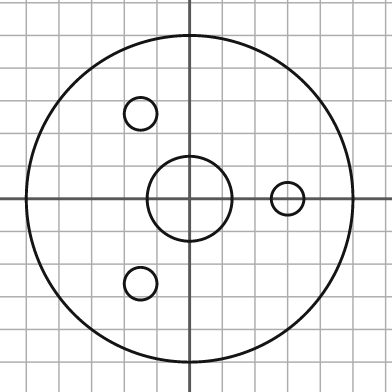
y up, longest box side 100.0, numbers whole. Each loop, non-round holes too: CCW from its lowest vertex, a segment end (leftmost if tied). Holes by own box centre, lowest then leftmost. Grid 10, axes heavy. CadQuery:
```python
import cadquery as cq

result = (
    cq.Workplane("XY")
    .moveTo(0.0, 0.0)
    .circle(50.0)
    .moveTo(-15.0, -26.0)
    .circle(5.0)
    .moveTo(0.0, 0.0)
    .circle(13.0)
    .moveTo(30.0, 0.0)
    .circle(5.0)
    .moveTo(-15.0, 26.0)
    .circle(5.0)
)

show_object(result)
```